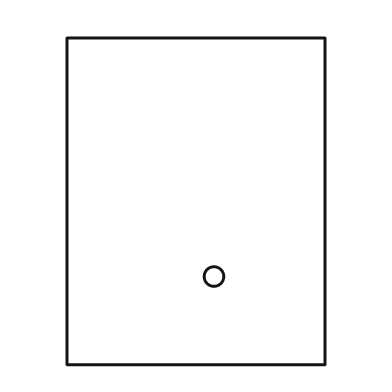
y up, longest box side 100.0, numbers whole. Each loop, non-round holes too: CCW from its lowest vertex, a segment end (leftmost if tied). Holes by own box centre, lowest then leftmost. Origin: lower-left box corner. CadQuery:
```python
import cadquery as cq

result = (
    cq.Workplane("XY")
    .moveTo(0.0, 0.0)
    .lineTo(79.0, 0.0)
    .lineTo(79.0, 100.0)
    .lineTo(0.0, 100.0)
    .close()
    .moveTo(45.0, 27.0)
    .circle(3.0)
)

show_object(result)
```